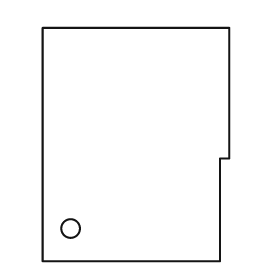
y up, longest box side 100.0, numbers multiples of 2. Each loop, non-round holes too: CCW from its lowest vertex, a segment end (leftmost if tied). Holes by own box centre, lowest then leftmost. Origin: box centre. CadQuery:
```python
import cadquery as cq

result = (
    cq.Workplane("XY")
    .moveTo(-40.0, -50.0)
    .lineTo(36.0, -50.0)
    .lineTo(36.0, -6.0)
    .lineTo(40.0, -6.0)
    .lineTo(40.0, 50.0)
    .lineTo(-40.0, 50.0)
    .close()
    .moveTo(-28.0, -36.0)
    .circle(4.0)
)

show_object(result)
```